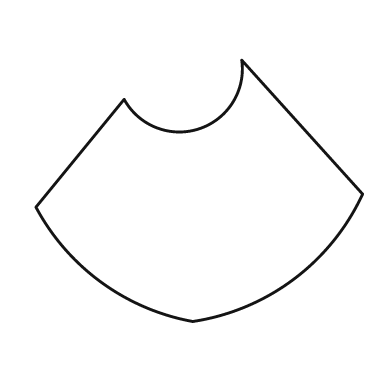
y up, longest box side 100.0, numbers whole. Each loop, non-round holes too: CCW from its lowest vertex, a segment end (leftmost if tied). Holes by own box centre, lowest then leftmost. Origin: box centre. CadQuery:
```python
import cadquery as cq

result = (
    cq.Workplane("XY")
    .moveTo(-2.0, -40.0)
    .threePointArc((29.0, -27.0), (50.0, -1.0))
    .lineTo(13.0, 40.0)
    .threePointArc((0.0, 19.0), (-23.0, 28.0))
    .lineTo(-50.0, -5.0)
    .threePointArc((-30.0, -28.0), (-2.0, -40.0))
    .close()
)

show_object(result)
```